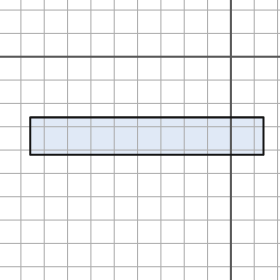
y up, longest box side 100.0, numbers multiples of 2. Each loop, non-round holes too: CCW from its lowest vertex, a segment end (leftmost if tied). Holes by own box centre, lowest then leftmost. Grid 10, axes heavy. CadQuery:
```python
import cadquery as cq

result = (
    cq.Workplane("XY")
    .moveTo(-86.0, -42.0)
    .lineTo(14.0, -42.0)
    .lineTo(14.0, -26.0)
    .lineTo(-86.0, -26.0)
    .close()
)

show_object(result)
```